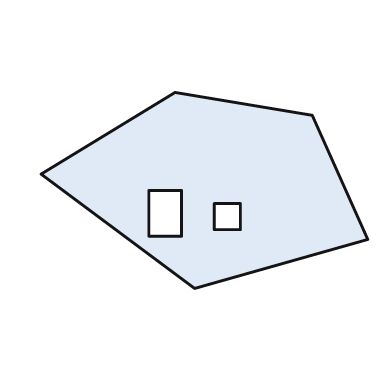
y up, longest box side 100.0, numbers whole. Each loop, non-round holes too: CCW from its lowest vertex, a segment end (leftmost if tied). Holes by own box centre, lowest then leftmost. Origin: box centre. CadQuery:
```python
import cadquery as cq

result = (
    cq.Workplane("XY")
    .moveTo(-3.0, -30.0)
    .lineTo(50.0, -15.0)
    .lineTo(33.0, 23.0)
    .lineTo(-9.0, 30.0)
    .lineTo(-50.0, 5.0)
    .close()
    .moveTo(3.0, -12.0)
    .lineTo(11.0, -12.0)
    .lineTo(11.0, -4.0)
    .lineTo(3.0, -4.0)
    .close()
    .moveTo(-17.0, -14.0)
    .lineTo(-7.0, -14.0)
    .lineTo(-7.0, 0.0)
    .lineTo(-17.0, 0.0)
    .close()
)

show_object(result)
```